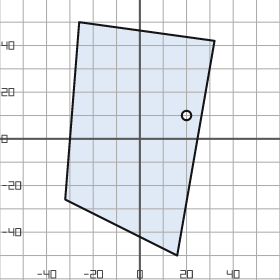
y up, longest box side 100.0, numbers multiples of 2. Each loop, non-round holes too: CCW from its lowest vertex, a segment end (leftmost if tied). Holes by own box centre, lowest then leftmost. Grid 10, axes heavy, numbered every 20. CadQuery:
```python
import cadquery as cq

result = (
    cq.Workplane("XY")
    .moveTo(16.0, -50.0)
    .lineTo(32.0, 42.0)
    .lineTo(-26.0, 50.0)
    .lineTo(-32.0, -26.0)
    .close()
    .moveTo(20.0, 10.0)
    .circle(2.0)
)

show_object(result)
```